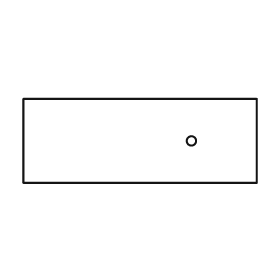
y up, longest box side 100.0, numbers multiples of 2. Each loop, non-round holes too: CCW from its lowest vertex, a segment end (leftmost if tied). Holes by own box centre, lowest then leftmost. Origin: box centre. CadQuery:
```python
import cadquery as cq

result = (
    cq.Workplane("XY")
    .moveTo(-50.0, -18.0)
    .lineTo(50.0, -18.0)
    .lineTo(50.0, 18.0)
    .lineTo(-50.0, 18.0)
    .close()
    .moveTo(22.0, 0.0)
    .circle(2.0)
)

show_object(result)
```